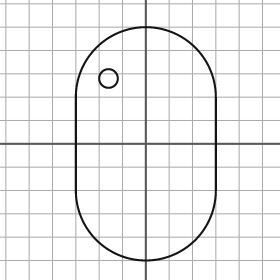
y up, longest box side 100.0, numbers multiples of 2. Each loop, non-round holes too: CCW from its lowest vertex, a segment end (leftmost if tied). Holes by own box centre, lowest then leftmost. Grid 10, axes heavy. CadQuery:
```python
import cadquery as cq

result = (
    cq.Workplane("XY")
    .moveTo(-30.0, -20.0)
    .threePointArc((0.0, -50.0), (30.0, -20.0))
    .lineTo(30.0, 20.0)
    .threePointArc((0.0, 50.0), (-30.0, 20.0))
    .close()
    .moveTo(-16.0, 28.0)
    .circle(4.0)
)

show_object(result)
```